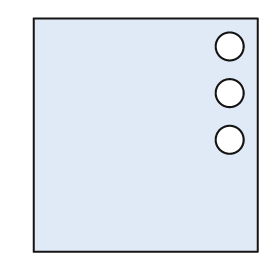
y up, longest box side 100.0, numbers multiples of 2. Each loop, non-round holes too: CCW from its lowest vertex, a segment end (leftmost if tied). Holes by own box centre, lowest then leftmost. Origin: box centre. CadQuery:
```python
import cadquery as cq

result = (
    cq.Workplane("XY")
    .moveTo(-48.0, -50.0)
    .lineTo(48.0, -50.0)
    .lineTo(48.0, 50.0)
    .lineTo(-48.0, 50.0)
    .close()
    .moveTo(36.0, -2.0)
    .circle(6.0)
    .moveTo(36.0, 18.0)
    .circle(6.0)
    .moveTo(36.0, 38.0)
    .circle(6.0)
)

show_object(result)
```